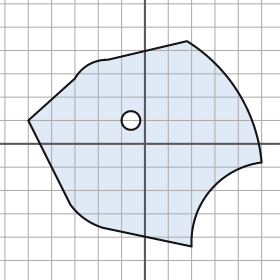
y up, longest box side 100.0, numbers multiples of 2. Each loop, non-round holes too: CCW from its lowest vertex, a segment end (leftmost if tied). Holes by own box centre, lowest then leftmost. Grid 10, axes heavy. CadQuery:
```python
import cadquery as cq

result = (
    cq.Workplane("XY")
    .moveTo(20.0, -44.0)
    .threePointArc((28.0, -20.0), (50.0, -8.0))
    .threePointArc((40.0, 22.0), (18.0, 44.0))
    .lineTo(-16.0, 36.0)
    .threePointArc((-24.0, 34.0), (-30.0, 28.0))
    .lineTo(-50.0, 10.0)
    .lineTo(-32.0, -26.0)
    .threePointArc((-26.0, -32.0), (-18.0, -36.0))
    .close()
    .moveTo(-6.0, 10.0)
    .circle(4.0)
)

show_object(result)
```